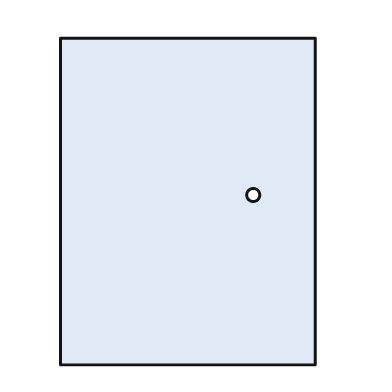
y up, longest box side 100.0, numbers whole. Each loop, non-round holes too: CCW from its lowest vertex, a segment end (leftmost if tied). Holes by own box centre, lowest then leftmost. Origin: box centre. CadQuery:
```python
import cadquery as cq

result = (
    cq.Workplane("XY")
    .moveTo(-39.0, -50.0)
    .lineTo(39.0, -50.0)
    .lineTo(39.0, 50.0)
    .lineTo(-39.0, 50.0)
    .close()
    .moveTo(20.0, 2.0)
    .circle(2.0)
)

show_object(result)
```